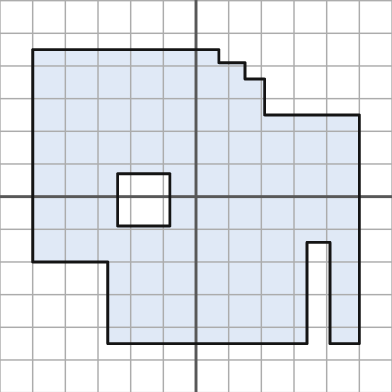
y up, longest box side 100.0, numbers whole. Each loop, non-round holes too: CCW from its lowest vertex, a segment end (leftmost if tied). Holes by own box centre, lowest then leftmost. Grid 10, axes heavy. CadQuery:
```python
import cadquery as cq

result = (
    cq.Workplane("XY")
    .moveTo(-27.0, -45.0)
    .lineTo(34.0, -45.0)
    .lineTo(34.0, -14.0)
    .lineTo(41.0, -14.0)
    .lineTo(41.0, -45.0)
    .lineTo(50.0, -45.0)
    .lineTo(50.0, 25.0)
    .lineTo(21.0, 25.0)
    .lineTo(21.0, 36.0)
    .lineTo(15.0, 36.0)
    .lineTo(15.0, 41.0)
    .lineTo(7.0, 41.0)
    .lineTo(7.0, 45.0)
    .lineTo(-50.0, 45.0)
    .lineTo(-50.0, -20.0)
    .lineTo(-27.0, -20.0)
    .close()
    .moveTo(-24.0, -9.0)
    .lineTo(-8.0, -9.0)
    .lineTo(-8.0, 7.0)
    .lineTo(-24.0, 7.0)
    .close()
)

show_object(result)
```